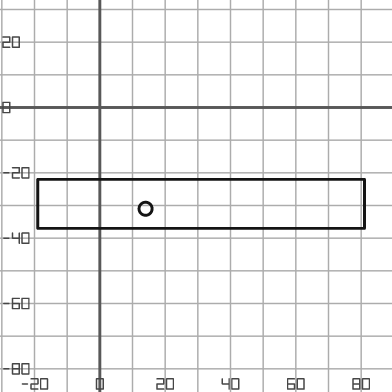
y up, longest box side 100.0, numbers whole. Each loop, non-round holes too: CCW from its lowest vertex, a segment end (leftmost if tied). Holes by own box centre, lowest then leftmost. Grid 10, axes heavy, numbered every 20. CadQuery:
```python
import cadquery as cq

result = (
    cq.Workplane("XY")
    .moveTo(-19.0, -37.0)
    .lineTo(81.0, -37.0)
    .lineTo(81.0, -22.0)
    .lineTo(-19.0, -22.0)
    .close()
    .moveTo(14.0, -31.0)
    .circle(2.0)
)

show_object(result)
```